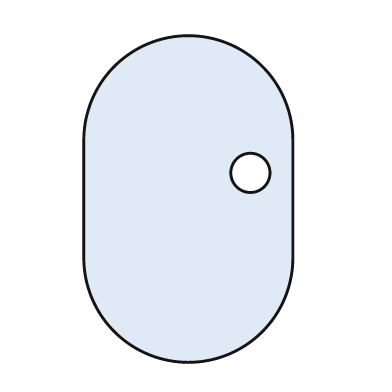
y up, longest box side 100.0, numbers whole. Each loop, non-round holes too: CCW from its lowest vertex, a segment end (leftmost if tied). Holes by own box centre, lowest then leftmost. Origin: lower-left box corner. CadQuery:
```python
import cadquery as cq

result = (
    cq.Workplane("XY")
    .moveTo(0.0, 32.0)
    .threePointArc((32.0, 0.0), (64.0, 32.0))
    .lineTo(64.0, 68.0)
    .threePointArc((32.0, 100.0), (0.0, 68.0))
    .close()
    .moveTo(51.0, 58.0)
    .circle(6.0)
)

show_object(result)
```